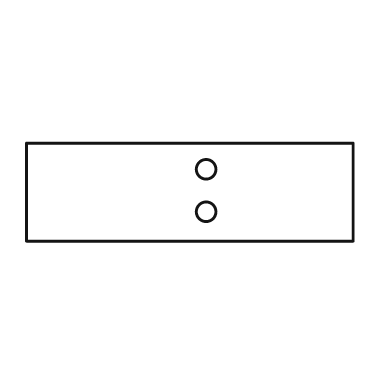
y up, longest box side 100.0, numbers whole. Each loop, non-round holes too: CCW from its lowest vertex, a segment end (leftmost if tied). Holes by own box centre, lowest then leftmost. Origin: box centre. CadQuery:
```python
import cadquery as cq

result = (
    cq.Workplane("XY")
    .moveTo(-50.0, -15.0)
    .lineTo(50.0, -15.0)
    .lineTo(50.0, 15.0)
    .lineTo(-50.0, 15.0)
    .close()
    .moveTo(5.0, -6.0)
    .circle(3.0)
    .moveTo(5.0, 7.0)
    .circle(3.0)
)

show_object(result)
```